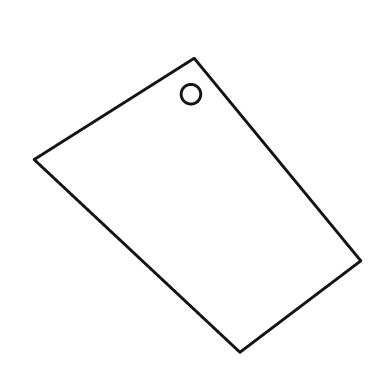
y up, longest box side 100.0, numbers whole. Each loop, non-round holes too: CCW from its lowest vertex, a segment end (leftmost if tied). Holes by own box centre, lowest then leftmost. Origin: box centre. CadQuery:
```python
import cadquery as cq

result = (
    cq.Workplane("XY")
    .moveTo(13.0, -45.0)
    .lineTo(50.0, -17.0)
    .lineTo(-1.0, 45.0)
    .lineTo(-50.0, 14.0)
    .close()
    .moveTo(-2.0, 34.0)
    .circle(3.0)
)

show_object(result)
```